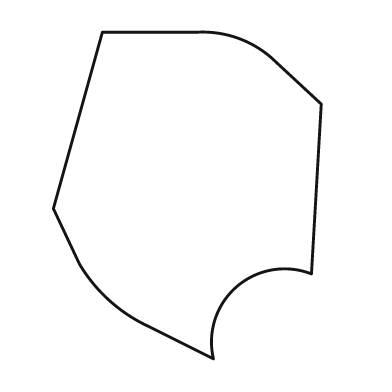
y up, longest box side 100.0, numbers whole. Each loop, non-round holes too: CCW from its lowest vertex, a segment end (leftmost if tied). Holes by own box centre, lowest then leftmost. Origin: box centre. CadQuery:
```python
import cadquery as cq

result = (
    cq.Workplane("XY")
    .moveTo(8.0, -50.0)
    .threePointArc((15.0, -28.0), (38.0, -24.0))
    .lineTo(41.0, 28.0)
    .lineTo(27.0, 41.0)
    .threePointArc((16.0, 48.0), (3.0, 50.0))
    .lineTo(-26.0, 50.0)
    .lineTo(-41.0, -4.0)
    .lineTo(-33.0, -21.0)
    .threePointArc((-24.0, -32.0), (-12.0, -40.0))
    .close()
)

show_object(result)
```